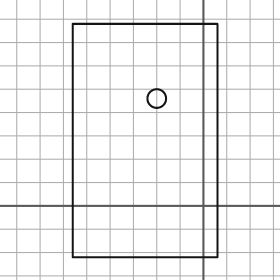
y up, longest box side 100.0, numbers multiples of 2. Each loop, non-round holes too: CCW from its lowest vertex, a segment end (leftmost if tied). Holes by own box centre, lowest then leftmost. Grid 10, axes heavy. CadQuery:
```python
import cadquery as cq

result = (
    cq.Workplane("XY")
    .moveTo(-56.0, -22.0)
    .lineTo(6.0, -22.0)
    .lineTo(6.0, 78.0)
    .lineTo(-56.0, 78.0)
    .close()
    .moveTo(-20.0, 46.0)
    .circle(4.0)
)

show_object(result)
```